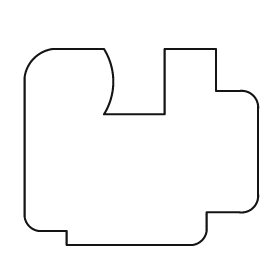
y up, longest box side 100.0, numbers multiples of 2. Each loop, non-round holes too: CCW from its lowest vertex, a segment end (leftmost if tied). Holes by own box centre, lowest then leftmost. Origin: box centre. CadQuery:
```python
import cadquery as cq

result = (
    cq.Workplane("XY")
    .moveTo(-32.0, -42.0)
    .lineTo(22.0, -42.0)
    .threePointArc((26.0, -40.0), (28.0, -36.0))
    .lineTo(28.0, -28.0)
    .lineTo(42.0, -28.0)
    .threePointArc((48.0, -26.0), (50.0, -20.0))
    .lineTo(50.0, 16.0)
    .threePointArc((48.0, 22.0), (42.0, 24.0))
    .lineTo(32.0, 24.0)
    .lineTo(32.0, 42.0)
    .lineTo(10.0, 42.0)
    .lineTo(10.0, 14.0)
    .lineTo(-16.0, 14.0)
    .threePointArc((-12.0, 28.0), (-16.0, 42.0))
    .lineTo(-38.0, 42.0)
    .threePointArc((-46.0, 38.0), (-50.0, 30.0))
    .lineTo(-50.0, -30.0)
    .threePointArc((-48.0, -34.0), (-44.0, -36.0))
    .lineTo(-32.0, -36.0)
    .close()
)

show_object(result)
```